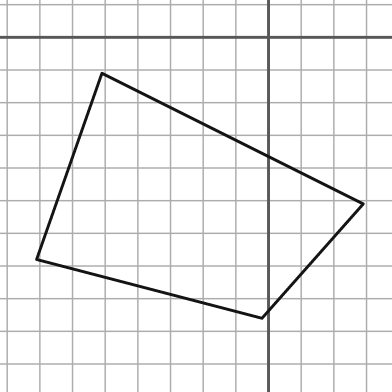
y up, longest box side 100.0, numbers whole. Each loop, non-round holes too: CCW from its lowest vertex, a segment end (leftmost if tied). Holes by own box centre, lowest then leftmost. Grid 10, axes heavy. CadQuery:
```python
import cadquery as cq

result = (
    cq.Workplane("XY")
    .moveTo(-2.0, -86.0)
    .lineTo(29.0, -51.0)
    .lineTo(-51.0, -11.0)
    .lineTo(-71.0, -68.0)
    .close()
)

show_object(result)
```